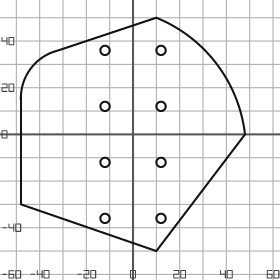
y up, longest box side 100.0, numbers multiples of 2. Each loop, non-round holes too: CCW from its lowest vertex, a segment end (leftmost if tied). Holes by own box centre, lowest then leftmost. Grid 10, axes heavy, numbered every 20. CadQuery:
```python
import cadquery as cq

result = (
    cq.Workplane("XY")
    .moveTo(10.0, -50.0)
    .lineTo(48.0, 0.0)
    .threePointArc((36.0, 30.0), (10.0, 50.0))
    .lineTo(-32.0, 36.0)
    .threePointArc((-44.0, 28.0), (-48.0, 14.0))
    .lineTo(-48.0, -30.0)
    .close()
    .moveTo(-12.0, -36.0)
    .circle(2.0)
    .moveTo(12.0, -36.0)
    .circle(2.0)
    .moveTo(-12.0, -12.0)
    .circle(2.0)
    .moveTo(12.0, -12.0)
    .circle(2.0)
    .moveTo(-12.0, 12.0)
    .circle(2.0)
    .moveTo(12.0, 12.0)
    .circle(2.0)
    .moveTo(-12.0, 36.0)
    .circle(2.0)
    .moveTo(12.0, 36.0)
    .circle(2.0)
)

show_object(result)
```